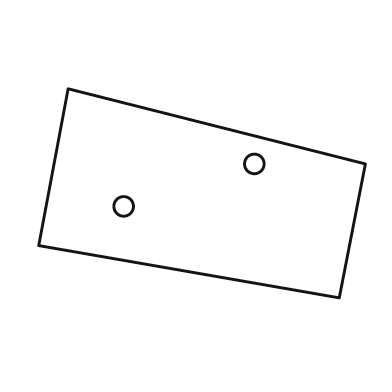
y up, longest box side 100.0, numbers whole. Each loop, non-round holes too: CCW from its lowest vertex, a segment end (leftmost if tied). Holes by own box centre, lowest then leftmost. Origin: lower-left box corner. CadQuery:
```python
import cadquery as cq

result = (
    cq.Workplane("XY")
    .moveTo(92.0, 0.0)
    .lineTo(100.0, 41.0)
    .lineTo(9.0, 64.0)
    .lineTo(0.0, 16.0)
    .close()
    .moveTo(26.0, 28.0)
    .circle(3.0)
    .moveTo(66.0, 41.0)
    .circle(3.0)
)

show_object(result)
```